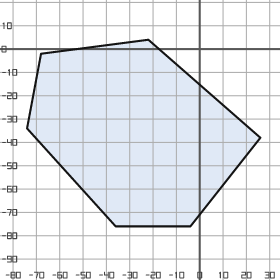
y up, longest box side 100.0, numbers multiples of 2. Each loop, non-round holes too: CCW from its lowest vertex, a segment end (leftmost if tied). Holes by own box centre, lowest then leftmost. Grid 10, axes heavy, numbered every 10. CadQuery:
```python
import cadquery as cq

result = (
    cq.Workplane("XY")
    .moveTo(-36.0, -76.0)
    .lineTo(-4.0, -76.0)
    .lineTo(26.0, -38.0)
    .lineTo(-22.0, 4.0)
    .lineTo(-68.0, -2.0)
    .lineTo(-74.0, -34.0)
    .close()
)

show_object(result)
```